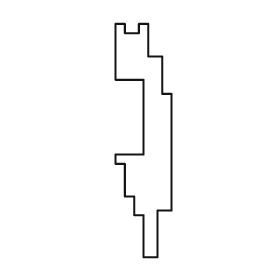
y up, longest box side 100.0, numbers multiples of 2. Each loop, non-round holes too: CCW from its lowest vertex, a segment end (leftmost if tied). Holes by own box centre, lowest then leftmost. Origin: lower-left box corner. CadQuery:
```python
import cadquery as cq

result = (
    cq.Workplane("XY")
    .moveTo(12.0, 0.0)
    .lineTo(18.0, 0.0)
    .lineTo(18.0, 20.0)
    .lineTo(24.0, 20.0)
    .lineTo(24.0, 70.0)
    .lineTo(20.0, 70.0)
    .lineTo(20.0, 86.0)
    .lineTo(14.0, 86.0)
    .lineTo(14.0, 100.0)
    .lineTo(10.0, 100.0)
    .lineTo(10.0, 96.0)
    .lineTo(4.0, 96.0)
    .lineTo(4.0, 100.0)
    .lineTo(0.0, 100.0)
    .lineTo(0.0, 76.0)
    .lineTo(12.0, 76.0)
    .lineTo(12.0, 44.0)
    .lineTo(0.0, 44.0)
    .lineTo(0.0, 40.0)
    .lineTo(4.0, 40.0)
    .lineTo(4.0, 26.0)
    .lineTo(8.0, 26.0)
    .lineTo(8.0, 18.0)
    .lineTo(12.0, 18.0)
    .close()
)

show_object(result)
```